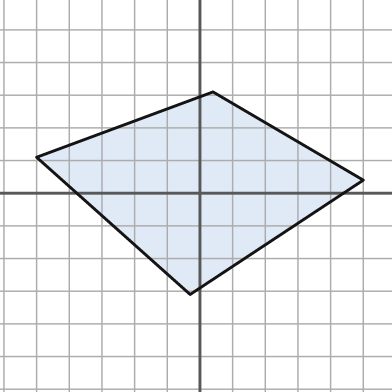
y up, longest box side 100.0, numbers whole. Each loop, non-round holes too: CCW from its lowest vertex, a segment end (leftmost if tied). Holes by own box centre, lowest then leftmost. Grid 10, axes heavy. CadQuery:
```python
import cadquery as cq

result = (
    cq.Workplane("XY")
    .moveTo(-3.0, -31.0)
    .lineTo(50.0, 4.0)
    .lineTo(4.0, 31.0)
    .lineTo(-50.0, 11.0)
    .close()
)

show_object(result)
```